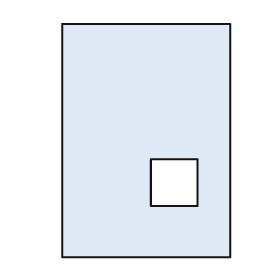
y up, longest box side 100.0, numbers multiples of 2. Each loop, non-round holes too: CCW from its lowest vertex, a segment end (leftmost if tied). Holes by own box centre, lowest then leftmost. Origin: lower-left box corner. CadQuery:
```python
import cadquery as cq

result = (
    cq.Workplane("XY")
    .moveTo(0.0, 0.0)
    .lineTo(72.0, 0.0)
    .lineTo(72.0, 100.0)
    .lineTo(0.0, 100.0)
    .close()
    .moveTo(38.0, 22.0)
    .lineTo(58.0, 22.0)
    .lineTo(58.0, 42.0)
    .lineTo(38.0, 42.0)
    .close()
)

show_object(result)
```